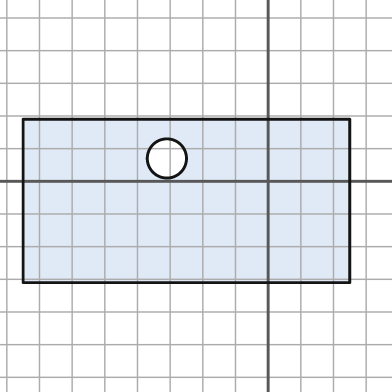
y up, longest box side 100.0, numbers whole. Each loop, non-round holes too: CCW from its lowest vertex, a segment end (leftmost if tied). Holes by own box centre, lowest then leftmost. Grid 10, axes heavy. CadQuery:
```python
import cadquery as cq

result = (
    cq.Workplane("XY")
    .moveTo(-75.0, -31.0)
    .lineTo(25.0, -31.0)
    .lineTo(25.0, 19.0)
    .lineTo(-75.0, 19.0)
    .close()
    .moveTo(-31.0, 7.0)
    .circle(6.0)
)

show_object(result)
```